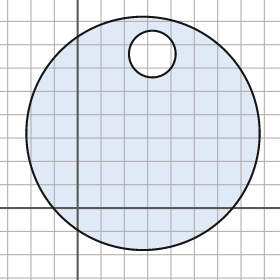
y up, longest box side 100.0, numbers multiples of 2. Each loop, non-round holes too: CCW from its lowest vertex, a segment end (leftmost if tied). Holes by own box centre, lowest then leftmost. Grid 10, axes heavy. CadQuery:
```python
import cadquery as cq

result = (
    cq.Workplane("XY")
    .moveTo(28.0, 32.0)
    .circle(50.0)
    .moveTo(32.0, 66.0)
    .circle(10.0)
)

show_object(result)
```